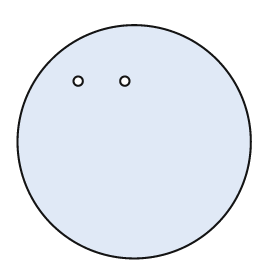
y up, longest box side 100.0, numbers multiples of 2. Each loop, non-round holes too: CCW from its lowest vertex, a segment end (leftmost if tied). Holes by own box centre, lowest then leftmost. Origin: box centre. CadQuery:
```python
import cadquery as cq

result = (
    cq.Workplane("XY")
    .moveTo(0.0, 0.0)
    .circle(50.0)
    .moveTo(-24.0, 26.0)
    .circle(2.0)
    .moveTo(-4.0, 26.0)
    .circle(2.0)
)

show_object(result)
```